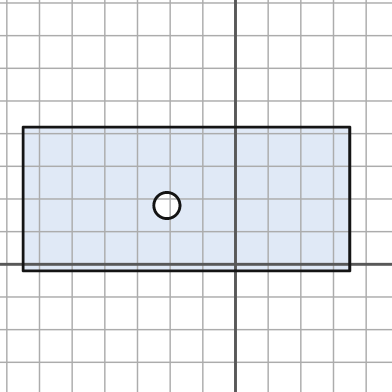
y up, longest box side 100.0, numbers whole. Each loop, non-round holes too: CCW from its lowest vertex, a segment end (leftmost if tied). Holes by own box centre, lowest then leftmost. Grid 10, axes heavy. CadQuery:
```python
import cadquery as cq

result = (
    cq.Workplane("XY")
    .moveTo(-65.0, -2.0)
    .lineTo(35.0, -2.0)
    .lineTo(35.0, 42.0)
    .lineTo(-65.0, 42.0)
    .close()
    .moveTo(-21.0, 18.0)
    .circle(4.0)
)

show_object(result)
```